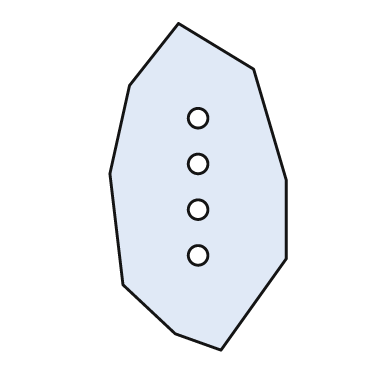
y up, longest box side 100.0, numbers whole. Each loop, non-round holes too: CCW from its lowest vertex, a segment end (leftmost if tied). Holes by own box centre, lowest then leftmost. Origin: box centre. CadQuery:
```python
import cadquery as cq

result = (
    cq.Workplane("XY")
    .moveTo(7.0, -50.0)
    .lineTo(27.0, -22.0)
    .lineTo(27.0, 2.0)
    .lineTo(17.0, 36.0)
    .lineTo(-6.0, 50.0)
    .lineTo(-21.0, 31.0)
    .lineTo(-27.0, 4.0)
    .lineTo(-23.0, -30.0)
    .lineTo(-7.0, -45.0)
    .close()
    .moveTo(0.0, -21.0)
    .circle(3.0)
    .moveTo(0.0, -7.0)
    .circle(3.0)
    .moveTo(0.0, 7.0)
    .circle(3.0)
    .moveTo(0.0, 21.0)
    .circle(3.0)
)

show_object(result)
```